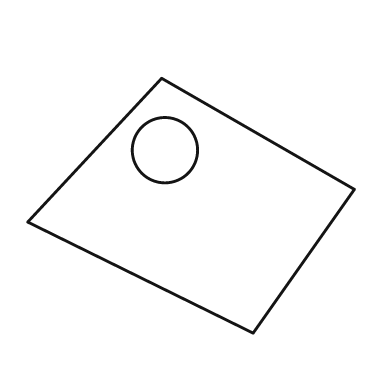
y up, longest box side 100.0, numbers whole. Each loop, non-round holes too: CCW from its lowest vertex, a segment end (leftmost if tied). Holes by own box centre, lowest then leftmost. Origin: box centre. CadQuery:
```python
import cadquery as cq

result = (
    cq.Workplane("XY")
    .moveTo(19.0, -39.0)
    .lineTo(50.0, 5.0)
    .lineTo(-9.0, 39.0)
    .lineTo(-50.0, -5.0)
    .close()
    .moveTo(-8.0, 17.0)
    .circle(10.0)
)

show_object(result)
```